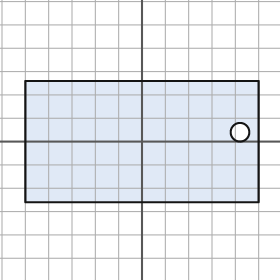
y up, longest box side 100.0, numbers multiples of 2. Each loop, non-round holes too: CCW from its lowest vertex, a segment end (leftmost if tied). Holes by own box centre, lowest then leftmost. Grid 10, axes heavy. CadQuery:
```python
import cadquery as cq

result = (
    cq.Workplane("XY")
    .moveTo(-50.0, -26.0)
    .lineTo(50.0, -26.0)
    .lineTo(50.0, 26.0)
    .lineTo(-50.0, 26.0)
    .close()
    .moveTo(42.0, 4.0)
    .circle(4.0)
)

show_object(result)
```